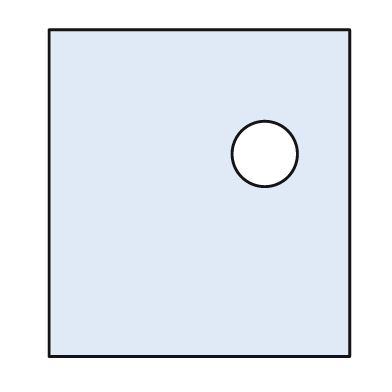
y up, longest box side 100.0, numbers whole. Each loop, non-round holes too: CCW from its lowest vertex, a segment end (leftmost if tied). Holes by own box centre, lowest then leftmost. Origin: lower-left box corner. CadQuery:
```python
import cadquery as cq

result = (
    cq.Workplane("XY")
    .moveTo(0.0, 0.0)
    .lineTo(92.0, 0.0)
    .lineTo(92.0, 100.0)
    .lineTo(0.0, 100.0)
    .close()
    .moveTo(66.0, 62.0)
    .circle(10.0)
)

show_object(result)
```